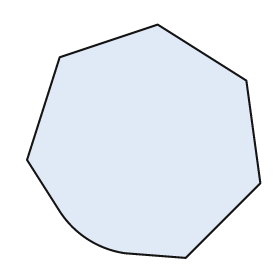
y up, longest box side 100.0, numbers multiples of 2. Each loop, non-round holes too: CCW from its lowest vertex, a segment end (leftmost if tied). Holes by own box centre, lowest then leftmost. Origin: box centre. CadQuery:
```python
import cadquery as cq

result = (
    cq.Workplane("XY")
    .moveTo(18.0, -50.0)
    .lineTo(50.0, -18.0)
    .lineTo(44.0, 26.0)
    .lineTo(6.0, 50.0)
    .lineTo(-36.0, 36.0)
    .lineTo(-50.0, -8.0)
    .lineTo(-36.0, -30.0)
    .threePointArc((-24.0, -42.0), (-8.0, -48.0))
    .close()
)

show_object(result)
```